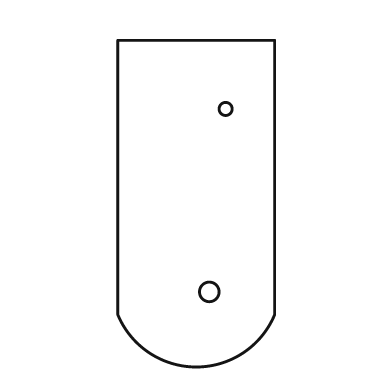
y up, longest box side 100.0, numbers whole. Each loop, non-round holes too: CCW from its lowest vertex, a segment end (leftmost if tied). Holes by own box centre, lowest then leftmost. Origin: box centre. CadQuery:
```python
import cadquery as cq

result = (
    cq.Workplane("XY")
    .moveTo(-24.0, -34.0)
    .threePointArc((0.0, -50.0), (24.0, -34.0))
    .lineTo(24.0, 50.0)
    .lineTo(-24.0, 50.0)
    .close()
    .moveTo(4.0, -27.0)
    .circle(3.0)
    .moveTo(9.0, 29.0)
    .circle(2.0)
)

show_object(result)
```